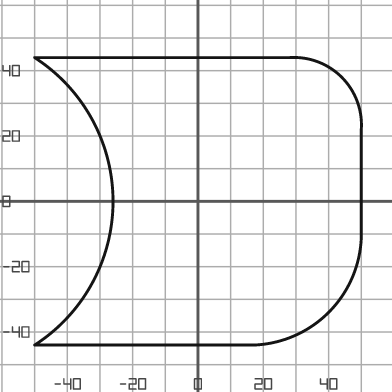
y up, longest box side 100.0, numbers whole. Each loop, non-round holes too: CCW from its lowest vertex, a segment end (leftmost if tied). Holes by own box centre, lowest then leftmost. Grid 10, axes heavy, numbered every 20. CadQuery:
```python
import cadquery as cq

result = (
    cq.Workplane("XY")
    .moveTo(-50.0, -44.0)
    .lineTo(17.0, -44.0)
    .threePointArc((40.0, -34.0), (50.0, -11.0))
    .lineTo(50.0, 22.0)
    .threePointArc((44.0, 38.0), (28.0, 44.0))
    .lineTo(-50.0, 44.0)
    .threePointArc((-26.0, 0.0), (-50.0, -44.0))
    .close()
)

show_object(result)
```